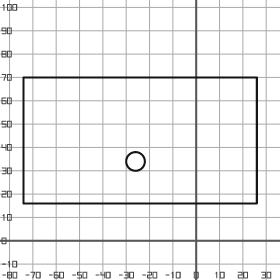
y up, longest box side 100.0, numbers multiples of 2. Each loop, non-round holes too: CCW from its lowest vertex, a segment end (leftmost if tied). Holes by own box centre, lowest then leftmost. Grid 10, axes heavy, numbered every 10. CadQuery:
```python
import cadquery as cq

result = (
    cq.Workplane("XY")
    .moveTo(-74.0, 16.0)
    .lineTo(26.0, 16.0)
    .lineTo(26.0, 70.0)
    .lineTo(-74.0, 70.0)
    .close()
    .moveTo(-26.0, 34.0)
    .circle(4.0)
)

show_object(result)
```